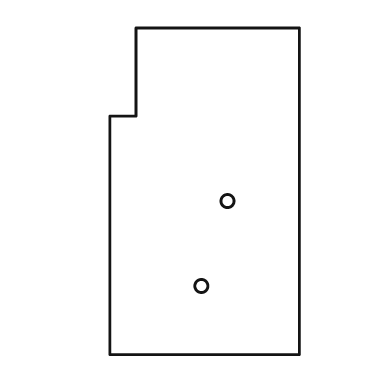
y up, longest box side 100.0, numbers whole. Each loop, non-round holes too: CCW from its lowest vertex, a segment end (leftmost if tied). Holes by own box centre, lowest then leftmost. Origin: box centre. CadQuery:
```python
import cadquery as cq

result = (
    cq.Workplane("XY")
    .moveTo(-29.0, -50.0)
    .lineTo(29.0, -50.0)
    .lineTo(29.0, 50.0)
    .lineTo(-21.0, 50.0)
    .lineTo(-21.0, 23.0)
    .lineTo(-29.0, 23.0)
    .close()
    .moveTo(-1.0, -29.0)
    .circle(2.0)
    .moveTo(7.0, -3.0)
    .circle(2.0)
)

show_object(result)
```